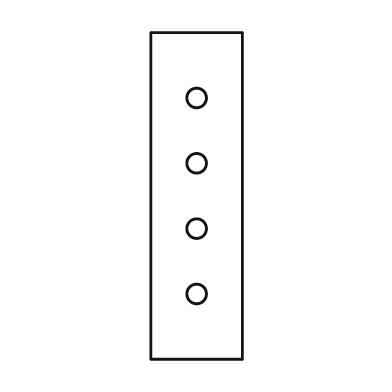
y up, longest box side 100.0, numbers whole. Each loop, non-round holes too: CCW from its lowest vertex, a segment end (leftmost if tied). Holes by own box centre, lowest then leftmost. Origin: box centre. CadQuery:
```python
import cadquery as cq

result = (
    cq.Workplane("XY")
    .moveTo(-14.0, -50.0)
    .lineTo(14.0, -50.0)
    .lineTo(14.0, 50.0)
    .lineTo(-14.0, 50.0)
    .close()
    .moveTo(0.0, -30.0)
    .circle(3.0)
    .moveTo(0.0, -10.0)
    .circle(3.0)
    .moveTo(0.0, 10.0)
    .circle(3.0)
    .moveTo(0.0, 30.0)
    .circle(3.0)
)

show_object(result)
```